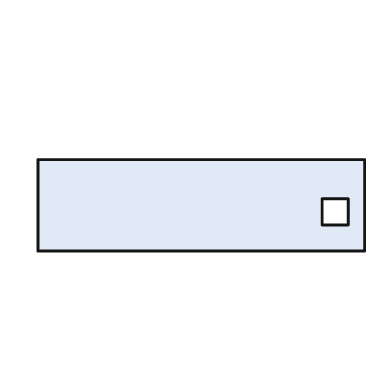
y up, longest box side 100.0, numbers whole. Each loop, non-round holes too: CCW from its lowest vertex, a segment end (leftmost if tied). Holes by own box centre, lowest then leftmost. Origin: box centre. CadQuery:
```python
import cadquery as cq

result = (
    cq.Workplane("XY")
    .moveTo(-50.0, -14.0)
    .lineTo(50.0, -14.0)
    .lineTo(50.0, 14.0)
    .lineTo(-50.0, 14.0)
    .close()
    .moveTo(37.0, -6.0)
    .lineTo(45.0, -6.0)
    .lineTo(45.0, 2.0)
    .lineTo(37.0, 2.0)
    .close()
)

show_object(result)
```